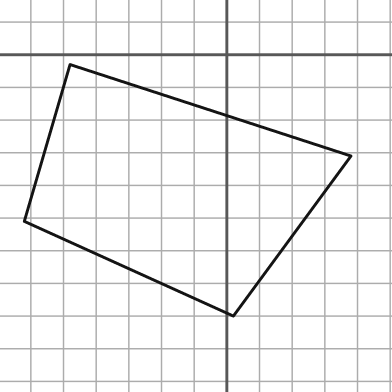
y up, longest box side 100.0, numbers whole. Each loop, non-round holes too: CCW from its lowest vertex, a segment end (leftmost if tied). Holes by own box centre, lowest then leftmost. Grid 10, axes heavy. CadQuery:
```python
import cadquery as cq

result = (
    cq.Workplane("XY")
    .moveTo(2.0, -80.0)
    .lineTo(38.0, -31.0)
    .lineTo(-48.0, -3.0)
    .lineTo(-62.0, -51.0)
    .close()
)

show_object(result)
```